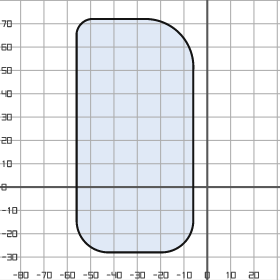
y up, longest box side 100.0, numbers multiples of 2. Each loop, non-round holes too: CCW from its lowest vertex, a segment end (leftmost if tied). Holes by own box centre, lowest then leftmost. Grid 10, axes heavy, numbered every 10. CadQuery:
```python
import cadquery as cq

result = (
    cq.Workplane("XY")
    .moveTo(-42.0, -28.0)
    .lineTo(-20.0, -28.0)
    .threePointArc((-10.0, -24.0), (-6.0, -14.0))
    .lineTo(-6.0, 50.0)
    .threePointArc((-12.0, 66.0), (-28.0, 72.0))
    .lineTo(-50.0, 72.0)
    .threePointArc((-54.0, 70.0), (-56.0, 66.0))
    .lineTo(-56.0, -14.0)
    .threePointArc((-52.0, -24.0), (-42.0, -28.0))
    .close()
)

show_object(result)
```